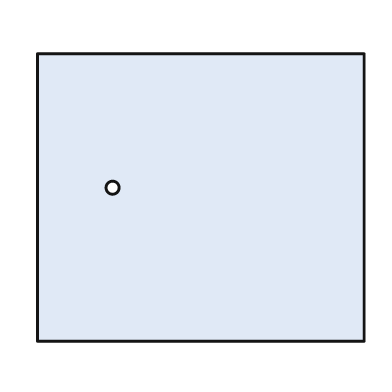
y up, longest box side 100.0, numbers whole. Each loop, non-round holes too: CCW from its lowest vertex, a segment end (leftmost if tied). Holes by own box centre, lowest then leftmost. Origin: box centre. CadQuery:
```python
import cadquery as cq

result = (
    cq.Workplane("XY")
    .moveTo(-50.0, -44.0)
    .lineTo(50.0, -44.0)
    .lineTo(50.0, 44.0)
    .lineTo(-50.0, 44.0)
    .close()
    .moveTo(-27.0, 3.0)
    .circle(2.0)
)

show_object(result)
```